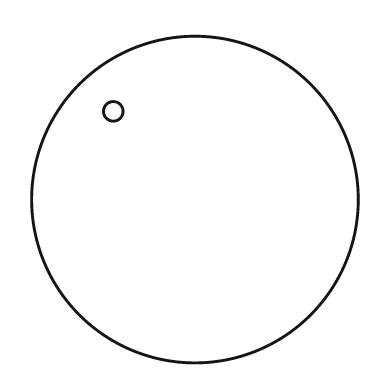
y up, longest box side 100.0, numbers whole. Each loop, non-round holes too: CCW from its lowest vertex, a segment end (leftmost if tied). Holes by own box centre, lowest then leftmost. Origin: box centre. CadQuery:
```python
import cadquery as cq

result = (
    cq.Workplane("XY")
    .moveTo(0.0, 0.0)
    .circle(50.0)
    .moveTo(-25.0, 27.0)
    .circle(3.0)
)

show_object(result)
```